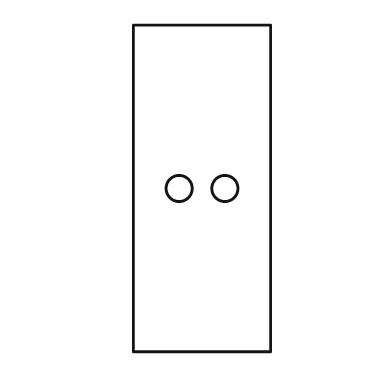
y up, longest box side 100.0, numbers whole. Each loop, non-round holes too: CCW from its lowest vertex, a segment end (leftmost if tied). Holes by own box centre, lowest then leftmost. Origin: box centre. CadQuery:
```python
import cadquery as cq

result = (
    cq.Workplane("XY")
    .moveTo(-21.0, -50.0)
    .lineTo(21.0, -50.0)
    .lineTo(21.0, 50.0)
    .lineTo(-21.0, 50.0)
    .close()
    .moveTo(-7.0, 0.0)
    .circle(4.0)
    .moveTo(7.0, 0.0)
    .circle(4.0)
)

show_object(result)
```